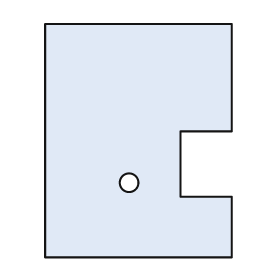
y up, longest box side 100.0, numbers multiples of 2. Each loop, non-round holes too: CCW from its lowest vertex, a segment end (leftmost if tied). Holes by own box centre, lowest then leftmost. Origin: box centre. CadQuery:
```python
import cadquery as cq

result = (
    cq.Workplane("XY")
    .moveTo(-40.0, -50.0)
    .lineTo(40.0, -50.0)
    .lineTo(40.0, -24.0)
    .lineTo(18.0, -24.0)
    .lineTo(18.0, 4.0)
    .lineTo(40.0, 4.0)
    .lineTo(40.0, 50.0)
    .lineTo(-40.0, 50.0)
    .close()
    .moveTo(-4.0, -18.0)
    .circle(4.0)
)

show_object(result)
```